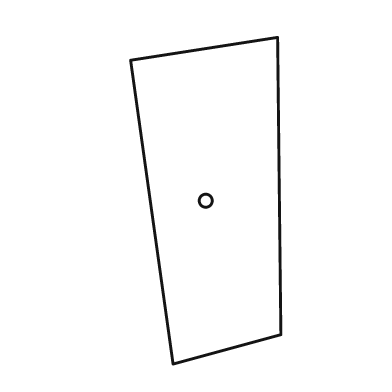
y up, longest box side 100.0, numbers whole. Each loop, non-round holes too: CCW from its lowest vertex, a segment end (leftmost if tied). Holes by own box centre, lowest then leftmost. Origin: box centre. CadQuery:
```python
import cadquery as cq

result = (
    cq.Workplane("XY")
    .moveTo(-10.0, -50.0)
    .lineTo(23.0, -41.0)
    .lineTo(22.0, 50.0)
    .lineTo(-23.0, 43.0)
    .close()
    .moveTo(0.0, 0.0)
    .circle(2.0)
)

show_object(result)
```